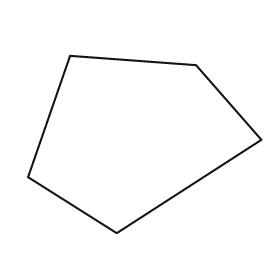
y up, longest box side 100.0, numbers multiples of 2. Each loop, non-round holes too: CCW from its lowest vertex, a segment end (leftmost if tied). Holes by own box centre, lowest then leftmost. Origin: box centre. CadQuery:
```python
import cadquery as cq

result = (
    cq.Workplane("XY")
    .moveTo(-12.0, -38.0)
    .lineTo(50.0, 2.0)
    .lineTo(22.0, 34.0)
    .lineTo(-32.0, 38.0)
    .lineTo(-50.0, -14.0)
    .close()
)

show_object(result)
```